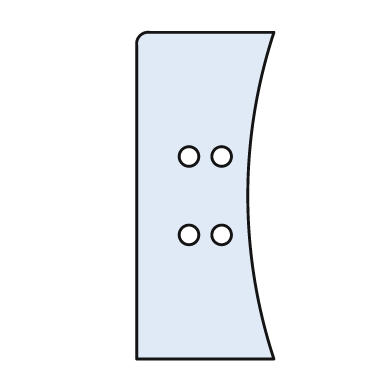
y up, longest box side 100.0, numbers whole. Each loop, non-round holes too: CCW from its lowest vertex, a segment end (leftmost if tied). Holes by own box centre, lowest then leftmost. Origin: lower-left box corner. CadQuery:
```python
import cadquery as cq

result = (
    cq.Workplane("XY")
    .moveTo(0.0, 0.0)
    .lineTo(42.0, 0.0)
    .threePointArc((34.0, 50.0), (42.0, 100.0))
    .lineTo(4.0, 100.0)
    .threePointArc((1.0, 99.0), (0.0, 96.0))
    .close()
    .moveTo(16.0, 38.0)
    .circle(3.0)
    .moveTo(26.0, 38.0)
    .circle(3.0)
    .moveTo(16.0, 62.0)
    .circle(3.0)
    .moveTo(26.0, 62.0)
    .circle(3.0)
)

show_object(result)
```